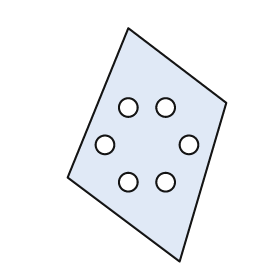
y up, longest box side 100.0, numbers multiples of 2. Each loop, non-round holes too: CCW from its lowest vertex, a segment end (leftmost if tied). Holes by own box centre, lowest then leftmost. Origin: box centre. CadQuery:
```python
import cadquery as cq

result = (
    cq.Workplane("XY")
    .moveTo(14.0, -50.0)
    .lineTo(34.0, 18.0)
    .lineTo(-8.0, 50.0)
    .lineTo(-34.0, -14.0)
    .close()
    .moveTo(-8.0, -16.0)
    .circle(4.0)
    .moveTo(8.0, -16.0)
    .circle(4.0)
    .moveTo(-18.0, 0.0)
    .circle(4.0)
    .moveTo(18.0, 0.0)
    .circle(4.0)
    .moveTo(-8.0, 16.0)
    .circle(4.0)
    .moveTo(8.0, 16.0)
    .circle(4.0)
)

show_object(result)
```